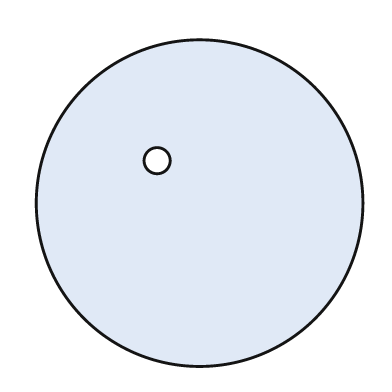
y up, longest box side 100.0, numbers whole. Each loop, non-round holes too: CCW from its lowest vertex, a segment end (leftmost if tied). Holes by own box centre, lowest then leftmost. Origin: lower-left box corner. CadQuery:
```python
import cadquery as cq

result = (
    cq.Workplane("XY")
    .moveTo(50.0, 50.0)
    .circle(50.0)
    .moveTo(37.0, 63.0)
    .circle(4.0)
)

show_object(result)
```